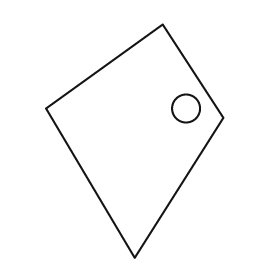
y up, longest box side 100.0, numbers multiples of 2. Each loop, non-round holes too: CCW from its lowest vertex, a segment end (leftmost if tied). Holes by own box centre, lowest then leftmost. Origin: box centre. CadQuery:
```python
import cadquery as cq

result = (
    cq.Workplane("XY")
    .moveTo(0.0, -50.0)
    .lineTo(38.0, 10.0)
    .lineTo(12.0, 50.0)
    .lineTo(-38.0, 14.0)
    .close()
    .moveTo(22.0, 14.0)
    .circle(6.0)
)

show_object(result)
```